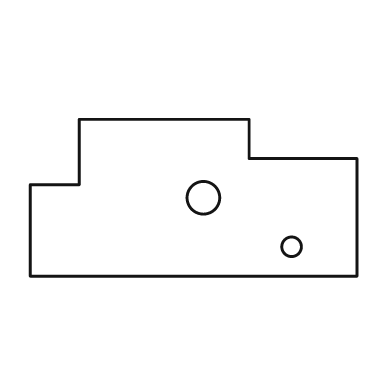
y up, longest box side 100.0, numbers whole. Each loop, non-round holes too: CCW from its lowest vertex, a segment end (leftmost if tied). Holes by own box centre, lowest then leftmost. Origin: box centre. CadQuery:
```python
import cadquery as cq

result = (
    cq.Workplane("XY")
    .moveTo(-50.0, -24.0)
    .lineTo(50.0, -24.0)
    .lineTo(50.0, 12.0)
    .lineTo(17.0, 12.0)
    .lineTo(17.0, 24.0)
    .lineTo(-35.0, 24.0)
    .lineTo(-35.0, 4.0)
    .lineTo(-50.0, 4.0)
    .close()
    .moveTo(30.0, -15.0)
    .circle(3.0)
    .moveTo(3.0, 0.0)
    .circle(5.0)
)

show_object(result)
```